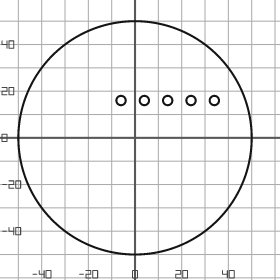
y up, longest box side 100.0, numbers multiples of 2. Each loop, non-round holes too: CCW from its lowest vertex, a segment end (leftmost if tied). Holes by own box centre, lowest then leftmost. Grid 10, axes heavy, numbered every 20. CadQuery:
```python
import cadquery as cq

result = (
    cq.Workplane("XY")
    .moveTo(0.0, 0.0)
    .circle(50.0)
    .moveTo(-6.0, 16.0)
    .circle(2.0)
    .moveTo(4.0, 16.0)
    .circle(2.0)
    .moveTo(14.0, 16.0)
    .circle(2.0)
    .moveTo(24.0, 16.0)
    .circle(2.0)
    .moveTo(34.0, 16.0)
    .circle(2.0)
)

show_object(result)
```